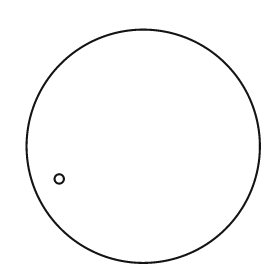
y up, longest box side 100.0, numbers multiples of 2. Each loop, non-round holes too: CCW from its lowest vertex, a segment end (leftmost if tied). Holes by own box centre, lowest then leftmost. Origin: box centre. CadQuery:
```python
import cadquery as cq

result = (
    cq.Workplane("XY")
    .moveTo(0.0, 0.0)
    .circle(50.0)
    .moveTo(-36.0, -14.0)
    .circle(2.0)
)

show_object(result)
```